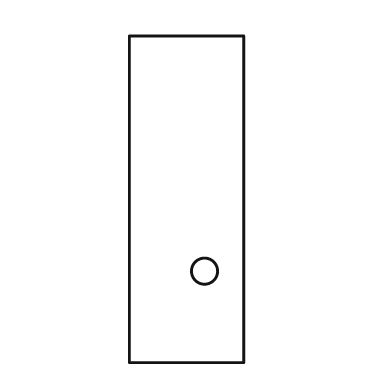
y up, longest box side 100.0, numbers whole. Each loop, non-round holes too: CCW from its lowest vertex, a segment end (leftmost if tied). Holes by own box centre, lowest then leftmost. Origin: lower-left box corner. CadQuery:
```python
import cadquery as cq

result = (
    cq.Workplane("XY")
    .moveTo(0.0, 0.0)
    .lineTo(35.0, 0.0)
    .lineTo(35.0, 100.0)
    .lineTo(0.0, 100.0)
    .close()
    .moveTo(23.0, 28.0)
    .circle(4.0)
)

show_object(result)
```